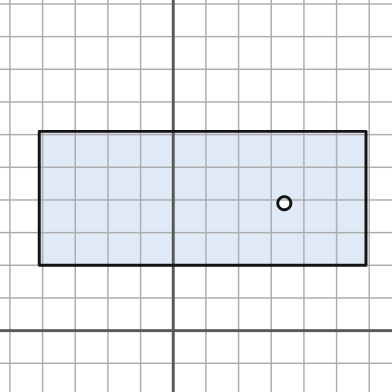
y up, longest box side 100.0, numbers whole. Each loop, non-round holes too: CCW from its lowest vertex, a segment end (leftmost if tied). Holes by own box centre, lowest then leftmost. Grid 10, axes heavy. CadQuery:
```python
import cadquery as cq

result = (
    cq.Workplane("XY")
    .moveTo(-41.0, 20.0)
    .lineTo(59.0, 20.0)
    .lineTo(59.0, 61.0)
    .lineTo(-41.0, 61.0)
    .close()
    .moveTo(34.0, 39.0)
    .circle(2.0)
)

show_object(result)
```